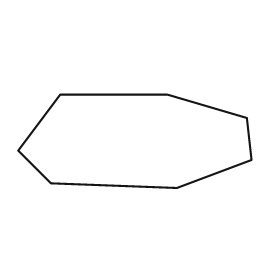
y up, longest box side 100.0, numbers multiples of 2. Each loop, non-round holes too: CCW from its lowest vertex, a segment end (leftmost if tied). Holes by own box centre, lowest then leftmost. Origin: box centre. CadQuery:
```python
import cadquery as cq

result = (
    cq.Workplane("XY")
    .moveTo(18.0, -20.0)
    .lineTo(50.0, -8.0)
    .lineTo(48.0, 10.0)
    .lineTo(14.0, 20.0)
    .lineTo(-32.0, 20.0)
    .lineTo(-50.0, -4.0)
    .lineTo(-36.0, -18.0)
    .close()
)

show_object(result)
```